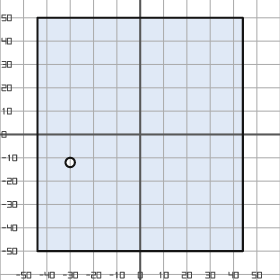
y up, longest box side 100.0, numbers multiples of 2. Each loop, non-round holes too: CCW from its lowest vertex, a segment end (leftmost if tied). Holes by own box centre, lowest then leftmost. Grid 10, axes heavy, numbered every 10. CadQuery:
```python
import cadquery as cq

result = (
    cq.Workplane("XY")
    .moveTo(-44.0, -50.0)
    .lineTo(44.0, -50.0)
    .lineTo(44.0, 50.0)
    .lineTo(-44.0, 50.0)
    .close()
    .moveTo(-30.0, -12.0)
    .circle(2.0)
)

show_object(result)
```